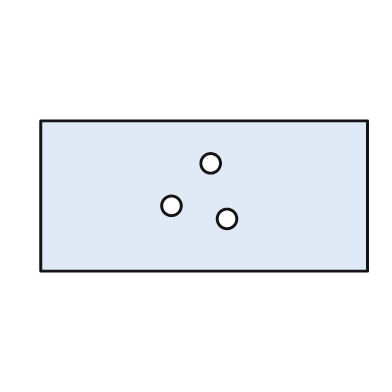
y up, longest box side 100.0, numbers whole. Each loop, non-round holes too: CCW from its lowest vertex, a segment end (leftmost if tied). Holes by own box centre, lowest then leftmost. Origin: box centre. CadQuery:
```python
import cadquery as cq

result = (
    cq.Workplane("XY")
    .moveTo(-50.0, -23.0)
    .lineTo(50.0, -23.0)
    .lineTo(50.0, 23.0)
    .lineTo(-50.0, 23.0)
    .close()
    .moveTo(7.0, -7.0)
    .circle(3.0)
    .moveTo(-10.0, -3.0)
    .circle(3.0)
    .moveTo(2.0, 10.0)
    .circle(3.0)
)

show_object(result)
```